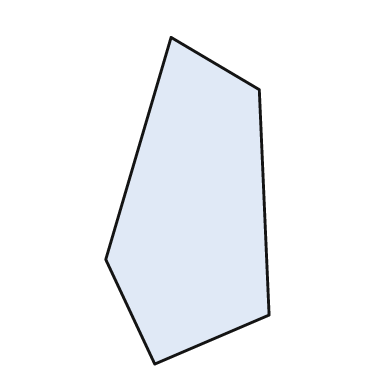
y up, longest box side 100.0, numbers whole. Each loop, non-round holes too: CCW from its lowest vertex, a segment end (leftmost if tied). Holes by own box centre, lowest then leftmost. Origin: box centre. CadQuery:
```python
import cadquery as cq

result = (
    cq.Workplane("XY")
    .moveTo(-10.0, -50.0)
    .lineTo(25.0, -35.0)
    .lineTo(22.0, 34.0)
    .lineTo(-5.0, 50.0)
    .lineTo(-25.0, -18.0)
    .close()
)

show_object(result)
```